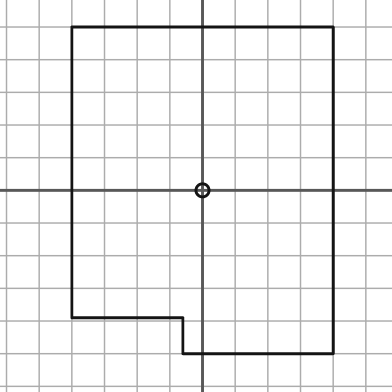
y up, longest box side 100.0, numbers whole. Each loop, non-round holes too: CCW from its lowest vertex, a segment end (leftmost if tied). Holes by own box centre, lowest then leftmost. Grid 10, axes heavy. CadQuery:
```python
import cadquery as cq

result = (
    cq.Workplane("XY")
    .moveTo(-6.0, -50.0)
    .lineTo(40.0, -50.0)
    .lineTo(40.0, 50.0)
    .lineTo(-40.0, 50.0)
    .lineTo(-40.0, -39.0)
    .lineTo(-6.0, -39.0)
    .close()
    .moveTo(0.0, 0.0)
    .circle(2.0)
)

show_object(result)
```